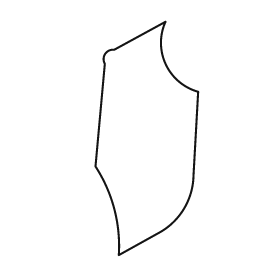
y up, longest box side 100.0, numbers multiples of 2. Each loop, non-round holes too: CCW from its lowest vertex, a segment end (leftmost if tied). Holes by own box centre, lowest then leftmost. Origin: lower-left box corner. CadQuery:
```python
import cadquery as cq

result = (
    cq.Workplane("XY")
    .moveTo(10.0, 0.0)
    .lineTo(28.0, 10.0)
    .threePointArc((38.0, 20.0), (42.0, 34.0))
    .lineTo(44.0, 70.0)
    .threePointArc((30.0, 82.0), (30.0, 100.0))
    .lineTo(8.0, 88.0)
    .threePointArc((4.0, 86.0), (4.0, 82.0))
    .lineTo(0.0, 38.0)
    .threePointArc((8.0, 20.0), (10.0, 0.0))
    .close()
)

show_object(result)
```